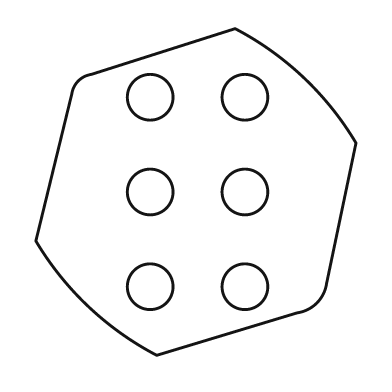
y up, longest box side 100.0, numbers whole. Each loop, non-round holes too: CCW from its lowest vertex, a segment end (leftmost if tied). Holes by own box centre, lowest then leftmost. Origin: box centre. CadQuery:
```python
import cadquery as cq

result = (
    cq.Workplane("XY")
    .moveTo(-12.0, -50.0)
    .lineTo(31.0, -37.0)
    .threePointArc((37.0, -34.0), (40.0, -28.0))
    .lineTo(49.0, 15.0)
    .threePointArc((33.0, 35.0), (12.0, 50.0))
    .lineTo(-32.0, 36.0)
    .threePointArc((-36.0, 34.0), (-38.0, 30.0))
    .lineTo(-49.0, -15.0)
    .threePointArc((-33.0, -35.0), (-12.0, -50.0))
    .close()
    .moveTo(-14.0, -29.0)
    .circle(7.0)
    .moveTo(15.0, -29.0)
    .circle(7.0)
    .moveTo(-14.0, 0.0)
    .circle(7.0)
    .moveTo(15.0, 0.0)
    .circle(7.0)
    .moveTo(-14.0, 29.0)
    .circle(7.0)
    .moveTo(15.0, 29.0)
    .circle(7.0)
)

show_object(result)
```